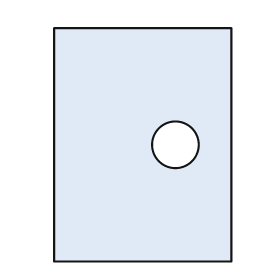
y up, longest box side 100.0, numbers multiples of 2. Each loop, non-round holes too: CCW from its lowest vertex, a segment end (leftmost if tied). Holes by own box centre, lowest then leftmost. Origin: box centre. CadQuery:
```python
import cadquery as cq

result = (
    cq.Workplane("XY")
    .moveTo(-38.0, -50.0)
    .lineTo(38.0, -50.0)
    .lineTo(38.0, 50.0)
    .lineTo(-38.0, 50.0)
    .close()
    .moveTo(14.0, 0.0)
    .circle(10.0)
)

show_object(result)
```